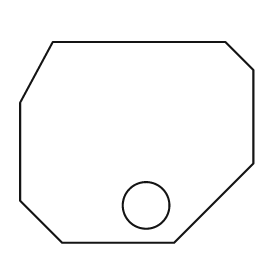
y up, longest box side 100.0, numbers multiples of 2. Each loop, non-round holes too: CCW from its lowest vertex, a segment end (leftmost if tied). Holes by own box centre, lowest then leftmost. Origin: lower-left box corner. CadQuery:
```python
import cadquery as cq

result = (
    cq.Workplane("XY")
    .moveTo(18.0, 0.0)
    .lineTo(66.0, 0.0)
    .lineTo(100.0, 34.0)
    .lineTo(100.0, 74.0)
    .lineTo(88.0, 86.0)
    .lineTo(14.0, 86.0)
    .lineTo(0.0, 60.0)
    .lineTo(0.0, 18.0)
    .close()
    .moveTo(54.0, 16.0)
    .circle(10.0)
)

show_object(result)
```